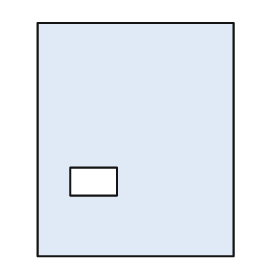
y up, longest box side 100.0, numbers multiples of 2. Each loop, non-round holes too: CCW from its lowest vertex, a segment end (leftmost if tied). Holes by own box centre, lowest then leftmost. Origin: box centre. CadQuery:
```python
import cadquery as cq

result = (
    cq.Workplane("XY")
    .moveTo(-42.0, -50.0)
    .lineTo(42.0, -50.0)
    .lineTo(42.0, 50.0)
    .lineTo(-42.0, 50.0)
    .close()
    .moveTo(-28.0, -24.0)
    .lineTo(-8.0, -24.0)
    .lineTo(-8.0, -12.0)
    .lineTo(-28.0, -12.0)
    .close()
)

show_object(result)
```